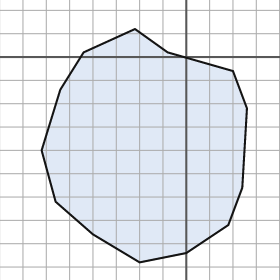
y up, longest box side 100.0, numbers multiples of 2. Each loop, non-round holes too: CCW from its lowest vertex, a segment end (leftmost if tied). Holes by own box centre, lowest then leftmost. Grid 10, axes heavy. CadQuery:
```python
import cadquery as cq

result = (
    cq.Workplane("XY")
    .moveTo(-20.0, -88.0)
    .lineTo(0.0, -84.0)
    .lineTo(18.0, -72.0)
    .lineTo(24.0, -56.0)
    .lineTo(26.0, -22.0)
    .lineTo(20.0, -6.0)
    .lineTo(-8.0, 2.0)
    .lineTo(-22.0, 12.0)
    .lineTo(-44.0, 2.0)
    .lineTo(-54.0, -14.0)
    .lineTo(-62.0, -40.0)
    .lineTo(-56.0, -62.0)
    .lineTo(-40.0, -76.0)
    .close()
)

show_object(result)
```